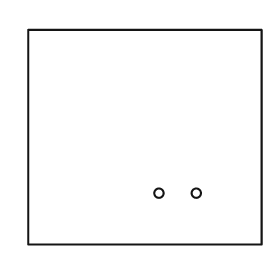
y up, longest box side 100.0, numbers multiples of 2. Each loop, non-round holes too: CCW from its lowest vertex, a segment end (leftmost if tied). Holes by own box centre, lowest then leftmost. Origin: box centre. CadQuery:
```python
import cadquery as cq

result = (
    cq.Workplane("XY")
    .moveTo(-50.0, -46.0)
    .lineTo(50.0, -46.0)
    .lineTo(50.0, 46.0)
    .lineTo(-50.0, 46.0)
    .close()
    .moveTo(6.0, -24.0)
    .circle(2.0)
    .moveTo(22.0, -24.0)
    .circle(2.0)
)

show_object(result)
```